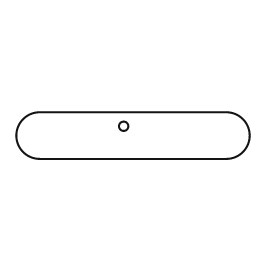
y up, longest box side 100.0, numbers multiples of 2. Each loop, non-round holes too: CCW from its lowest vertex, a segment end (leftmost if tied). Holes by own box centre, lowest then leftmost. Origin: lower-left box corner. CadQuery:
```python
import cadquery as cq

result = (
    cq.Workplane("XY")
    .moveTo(10.0, 0.0)
    .lineTo(90.0, 0.0)
    .threePointArc((100.0, 10.0), (90.0, 20.0))
    .lineTo(10.0, 20.0)
    .threePointArc((0.0, 10.0), (10.0, 0.0))
    .close()
    .moveTo(46.0, 14.0)
    .circle(2.0)
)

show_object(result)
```